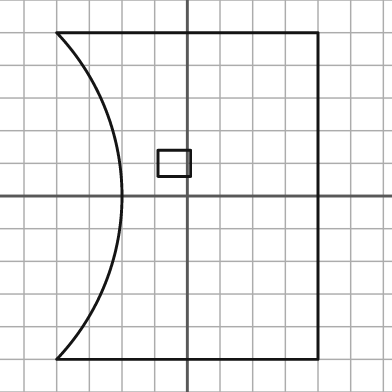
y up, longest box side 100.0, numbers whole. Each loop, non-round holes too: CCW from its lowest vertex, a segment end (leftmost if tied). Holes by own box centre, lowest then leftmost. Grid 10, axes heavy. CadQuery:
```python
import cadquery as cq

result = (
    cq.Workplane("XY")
    .moveTo(-40.0, -50.0)
    .lineTo(40.0, -50.0)
    .lineTo(40.0, 50.0)
    .lineTo(-40.0, 50.0)
    .threePointArc((-20.0, 0.0), (-40.0, -50.0))
    .close()
    .moveTo(-9.0, 6.0)
    .lineTo(1.0, 6.0)
    .lineTo(1.0, 14.0)
    .lineTo(-9.0, 14.0)
    .close()
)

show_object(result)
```